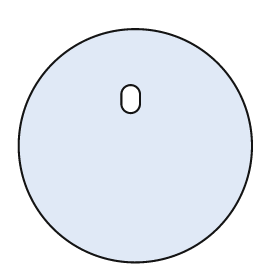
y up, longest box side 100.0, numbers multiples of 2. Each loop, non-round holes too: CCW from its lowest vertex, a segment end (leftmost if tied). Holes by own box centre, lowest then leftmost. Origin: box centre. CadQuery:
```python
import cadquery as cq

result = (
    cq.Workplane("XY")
    .moveTo(0.0, 0.0)
    .circle(50.0)
    .moveTo(-6.0, 18.0)
    .threePointArc((-2.0, 14.0), (2.0, 18.0))
    .lineTo(2.0, 22.0)
    .threePointArc((-2.0, 26.0), (-6.0, 22.0))
    .close()
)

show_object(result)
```